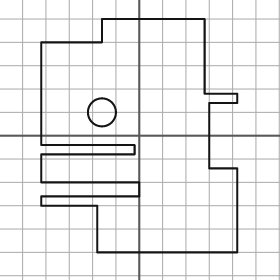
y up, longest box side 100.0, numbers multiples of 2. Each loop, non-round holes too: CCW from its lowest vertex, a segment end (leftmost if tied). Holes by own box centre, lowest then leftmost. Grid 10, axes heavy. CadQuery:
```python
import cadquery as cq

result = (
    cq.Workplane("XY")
    .moveTo(-18.0, -50.0)
    .lineTo(42.0, -50.0)
    .lineTo(42.0, -14.0)
    .lineTo(30.0, -14.0)
    .lineTo(30.0, 14.0)
    .lineTo(42.0, 14.0)
    .lineTo(42.0, 18.0)
    .lineTo(28.0, 18.0)
    .lineTo(28.0, 50.0)
    .lineTo(-16.0, 50.0)
    .lineTo(-16.0, 40.0)
    .lineTo(-42.0, 40.0)
    .lineTo(-42.0, -4.0)
    .lineTo(-2.0, -4.0)
    .lineTo(-2.0, -8.0)
    .lineTo(-42.0, -8.0)
    .lineTo(-42.0, -20.0)
    .lineTo(0.0, -20.0)
    .lineTo(0.0, -26.0)
    .lineTo(-42.0, -26.0)
    .lineTo(-42.0, -30.0)
    .lineTo(-18.0, -30.0)
    .close()
    .moveTo(-16.0, 10.0)
    .circle(6.0)
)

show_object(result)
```